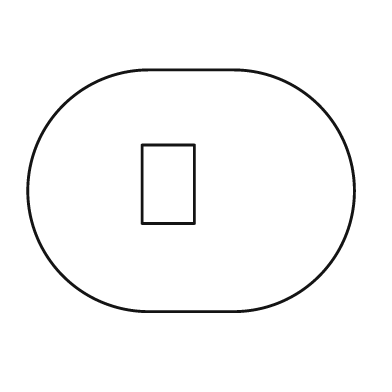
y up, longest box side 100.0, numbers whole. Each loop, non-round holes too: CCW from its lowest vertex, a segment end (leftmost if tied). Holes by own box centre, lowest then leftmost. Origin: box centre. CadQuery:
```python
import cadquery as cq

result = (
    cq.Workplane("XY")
    .moveTo(-13.0, -37.0)
    .lineTo(13.0, -37.0)
    .threePointArc((50.0, 0.0), (13.0, 37.0))
    .lineTo(-13.0, 37.0)
    .threePointArc((-50.0, 0.0), (-13.0, -37.0))
    .close()
    .moveTo(-15.0, -10.0)
    .lineTo(1.0, -10.0)
    .lineTo(1.0, 14.0)
    .lineTo(-15.0, 14.0)
    .close()
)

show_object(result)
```